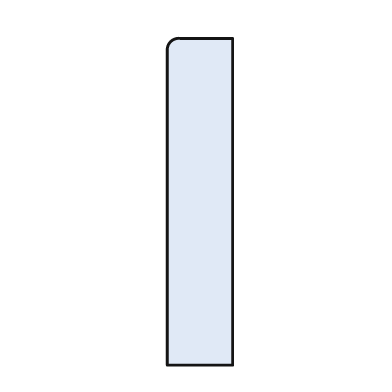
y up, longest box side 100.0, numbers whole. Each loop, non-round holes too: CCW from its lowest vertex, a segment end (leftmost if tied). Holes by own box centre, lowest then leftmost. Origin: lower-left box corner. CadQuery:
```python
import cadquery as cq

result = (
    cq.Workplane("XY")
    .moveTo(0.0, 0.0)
    .lineTo(20.0, 0.0)
    .lineTo(20.0, 100.0)
    .lineTo(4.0, 100.0)
    .threePointArc((1.0, 99.0), (0.0, 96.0))
    .close()
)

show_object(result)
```